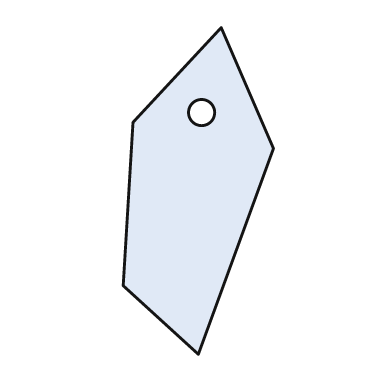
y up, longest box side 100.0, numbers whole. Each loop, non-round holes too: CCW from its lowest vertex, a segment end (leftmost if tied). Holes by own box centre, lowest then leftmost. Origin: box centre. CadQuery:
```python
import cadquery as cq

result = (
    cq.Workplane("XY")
    .moveTo(0.0, -50.0)
    .lineTo(23.0, 13.0)
    .lineTo(7.0, 50.0)
    .lineTo(-20.0, 21.0)
    .lineTo(-23.0, -29.0)
    .close()
    .moveTo(1.0, 24.0)
    .circle(4.0)
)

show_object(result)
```